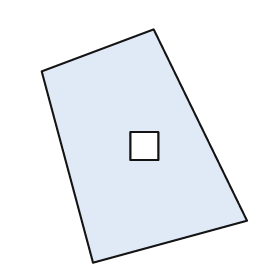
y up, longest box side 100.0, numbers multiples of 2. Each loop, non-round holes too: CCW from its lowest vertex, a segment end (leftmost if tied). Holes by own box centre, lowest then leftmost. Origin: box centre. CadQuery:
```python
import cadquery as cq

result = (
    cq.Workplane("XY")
    .moveTo(-22.0, -50.0)
    .lineTo(44.0, -32.0)
    .lineTo(4.0, 50.0)
    .lineTo(-44.0, 32.0)
    .close()
    .moveTo(-6.0, -6.0)
    .lineTo(6.0, -6.0)
    .lineTo(6.0, 6.0)
    .lineTo(-6.0, 6.0)
    .close()
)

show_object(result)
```